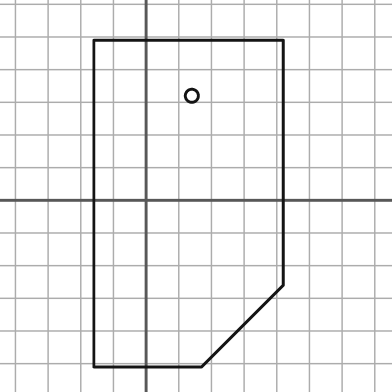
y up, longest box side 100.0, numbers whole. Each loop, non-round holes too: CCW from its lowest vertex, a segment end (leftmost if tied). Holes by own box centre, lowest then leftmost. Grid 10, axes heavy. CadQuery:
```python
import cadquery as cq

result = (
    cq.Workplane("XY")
    .moveTo(-16.0, -51.0)
    .lineTo(17.0, -51.0)
    .lineTo(42.0, -26.0)
    .lineTo(42.0, 49.0)
    .lineTo(-16.0, 49.0)
    .close()
    .moveTo(14.0, 32.0)
    .circle(2.0)
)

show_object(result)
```